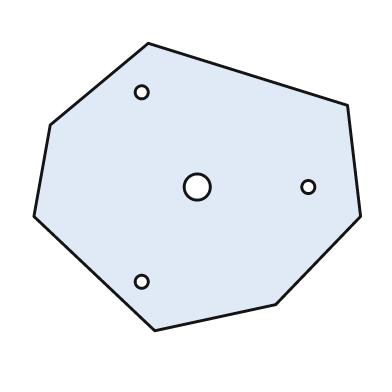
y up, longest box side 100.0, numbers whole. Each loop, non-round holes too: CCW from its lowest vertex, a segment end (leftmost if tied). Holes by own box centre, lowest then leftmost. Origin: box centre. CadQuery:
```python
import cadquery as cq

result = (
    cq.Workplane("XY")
    .moveTo(-13.0, -44.0)
    .lineTo(24.0, -36.0)
    .lineTo(50.0, -9.0)
    .lineTo(46.0, 25.0)
    .lineTo(-15.0, 44.0)
    .lineTo(-45.0, 19.0)
    .lineTo(-50.0, -9.0)
    .close()
    .moveTo(-17.0, -29.0)
    .circle(2.0)
    .moveTo(0.0, 0.0)
    .circle(4.0)
    .moveTo(34.0, 0.0)
    .circle(2.0)
    .moveTo(-17.0, 29.0)
    .circle(2.0)
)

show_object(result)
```